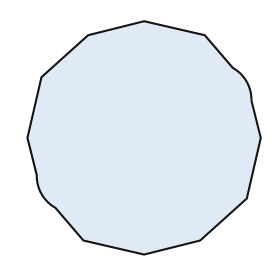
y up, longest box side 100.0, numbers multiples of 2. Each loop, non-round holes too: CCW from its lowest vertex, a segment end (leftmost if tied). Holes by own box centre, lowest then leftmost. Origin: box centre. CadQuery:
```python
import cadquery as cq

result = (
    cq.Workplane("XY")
    .moveTo(0.0, -50.0)
    .lineTo(24.0, -44.0)
    .lineTo(44.0, -26.0)
    .lineTo(50.0, 0.0)
    .lineTo(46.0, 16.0)
    .threePointArc((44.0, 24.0), (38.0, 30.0))
    .lineTo(26.0, 44.0)
    .lineTo(0.0, 50.0)
    .lineTo(-24.0, 44.0)
    .lineTo(-44.0, 26.0)
    .lineTo(-50.0, 0.0)
    .lineTo(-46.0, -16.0)
    .threePointArc((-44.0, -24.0), (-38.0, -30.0))
    .lineTo(-26.0, -44.0)
    .close()
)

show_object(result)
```